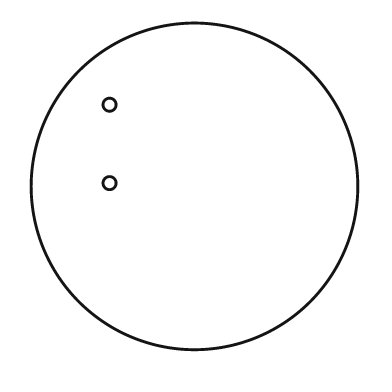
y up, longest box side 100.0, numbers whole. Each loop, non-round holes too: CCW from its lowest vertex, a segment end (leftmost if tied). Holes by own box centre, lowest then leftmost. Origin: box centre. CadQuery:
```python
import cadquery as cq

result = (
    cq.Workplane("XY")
    .moveTo(0.0, 0.0)
    .circle(50.0)
    .moveTo(-26.0, 1.0)
    .circle(2.0)
    .moveTo(-26.0, 25.0)
    .circle(2.0)
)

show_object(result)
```